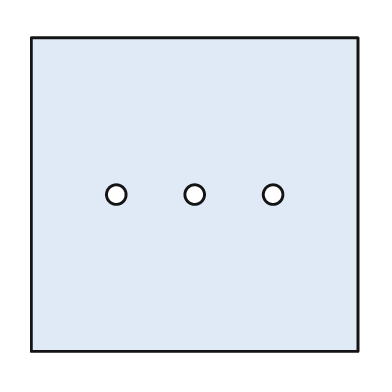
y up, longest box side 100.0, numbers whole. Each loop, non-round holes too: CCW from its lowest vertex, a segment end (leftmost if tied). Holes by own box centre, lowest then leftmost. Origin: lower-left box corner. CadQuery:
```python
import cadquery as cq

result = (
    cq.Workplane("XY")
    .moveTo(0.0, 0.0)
    .lineTo(100.0, 0.0)
    .lineTo(100.0, 96.0)
    .lineTo(0.0, 96.0)
    .close()
    .moveTo(26.0, 48.0)
    .circle(3.0)
    .moveTo(50.0, 48.0)
    .circle(3.0)
    .moveTo(74.0, 48.0)
    .circle(3.0)
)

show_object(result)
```